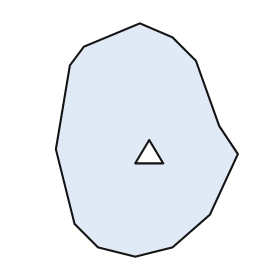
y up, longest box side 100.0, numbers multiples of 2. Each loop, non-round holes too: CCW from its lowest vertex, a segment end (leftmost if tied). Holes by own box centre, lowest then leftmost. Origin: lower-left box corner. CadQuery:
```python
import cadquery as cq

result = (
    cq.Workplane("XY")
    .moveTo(34.0, 0.0)
    .lineTo(50.0, 4.0)
    .lineTo(66.0, 18.0)
    .lineTo(78.0, 44.0)
    .lineTo(70.0, 56.0)
    .lineTo(60.0, 84.0)
    .lineTo(50.0, 94.0)
    .lineTo(36.0, 100.0)
    .lineTo(12.0, 90.0)
    .lineTo(6.0, 82.0)
    .lineTo(0.0, 46.0)
    .lineTo(8.0, 14.0)
    .lineTo(18.0, 4.0)
    .close()
    .moveTo(34.0, 40.0)
    .lineTo(46.0, 40.0)
    .lineTo(40.0, 50.0)
    .close()
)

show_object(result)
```